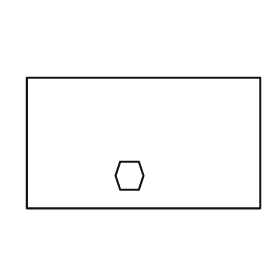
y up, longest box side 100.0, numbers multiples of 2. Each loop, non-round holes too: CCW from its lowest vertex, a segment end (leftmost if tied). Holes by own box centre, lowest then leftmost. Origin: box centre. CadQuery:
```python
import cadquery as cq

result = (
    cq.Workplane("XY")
    .moveTo(-50.0, -28.0)
    .lineTo(50.0, -28.0)
    .lineTo(50.0, 28.0)
    .lineTo(-50.0, 28.0)
    .close()
    .moveTo(-10.0, -20.0)
    .lineTo(-2.0, -20.0)
    .lineTo(0.0, -14.0)
    .lineTo(-2.0, -8.0)
    .lineTo(-10.0, -8.0)
    .lineTo(-12.0, -14.0)
    .close()
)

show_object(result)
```